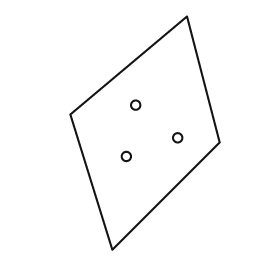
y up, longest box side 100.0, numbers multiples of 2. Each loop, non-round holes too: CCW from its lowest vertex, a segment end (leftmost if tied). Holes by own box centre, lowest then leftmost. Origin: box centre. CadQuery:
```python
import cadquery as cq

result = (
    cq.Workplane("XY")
    .moveTo(-14.0, -50.0)
    .lineTo(32.0, -4.0)
    .lineTo(18.0, 50.0)
    .lineTo(-32.0, 8.0)
    .close()
    .moveTo(-8.0, -10.0)
    .circle(2.0)
    .moveTo(14.0, -2.0)
    .circle(2.0)
    .moveTo(-4.0, 12.0)
    .circle(2.0)
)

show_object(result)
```